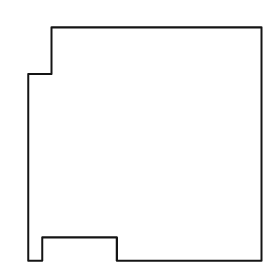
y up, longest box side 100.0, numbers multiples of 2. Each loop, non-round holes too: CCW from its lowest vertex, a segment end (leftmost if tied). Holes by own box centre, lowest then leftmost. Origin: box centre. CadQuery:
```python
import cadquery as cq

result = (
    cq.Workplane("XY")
    .moveTo(-50.0, -50.0)
    .lineTo(-44.0, -50.0)
    .lineTo(-44.0, -40.0)
    .lineTo(-12.0, -40.0)
    .lineTo(-12.0, -50.0)
    .lineTo(50.0, -50.0)
    .lineTo(50.0, 50.0)
    .lineTo(-40.0, 50.0)
    .lineTo(-40.0, 30.0)
    .lineTo(-50.0, 30.0)
    .close()
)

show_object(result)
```